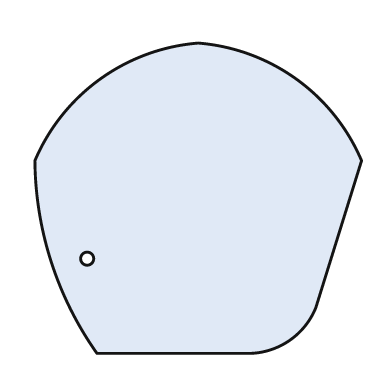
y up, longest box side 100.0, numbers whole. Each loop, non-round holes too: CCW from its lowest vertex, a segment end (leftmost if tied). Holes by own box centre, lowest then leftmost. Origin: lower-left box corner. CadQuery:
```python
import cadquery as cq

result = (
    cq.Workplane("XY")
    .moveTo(19.0, 0.0)
    .lineTo(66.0, 0.0)
    .threePointArc((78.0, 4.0), (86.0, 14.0))
    .lineTo(100.0, 59.0)
    .threePointArc((80.0, 84.0), (50.0, 95.0))
    .threePointArc((20.0, 84.0), (0.0, 59.0))
    .threePointArc((5.0, 28.0), (19.0, 0.0))
    .close()
    .moveTo(16.0, 29.0)
    .circle(2.0)
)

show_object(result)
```